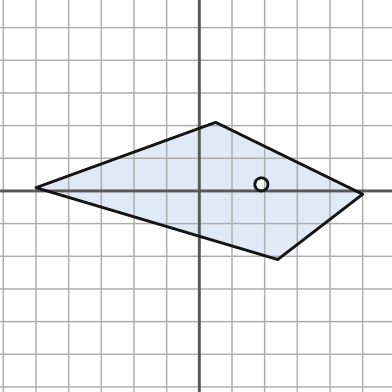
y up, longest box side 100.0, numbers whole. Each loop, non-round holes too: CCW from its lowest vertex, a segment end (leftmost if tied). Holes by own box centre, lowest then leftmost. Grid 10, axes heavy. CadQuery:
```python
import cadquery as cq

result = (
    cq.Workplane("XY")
    .moveTo(24.0, -21.0)
    .lineTo(50.0, -1.0)
    .lineTo(5.0, 21.0)
    .lineTo(-50.0, 1.0)
    .close()
    .moveTo(19.0, 2.0)
    .circle(2.0)
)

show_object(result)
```